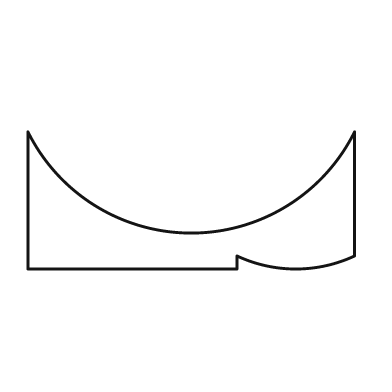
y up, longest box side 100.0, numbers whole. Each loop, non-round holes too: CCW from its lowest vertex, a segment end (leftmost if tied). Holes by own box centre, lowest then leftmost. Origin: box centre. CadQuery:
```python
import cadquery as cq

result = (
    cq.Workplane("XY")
    .moveTo(-50.0, -21.0)
    .lineTo(14.0, -21.0)
    .lineTo(14.0, -17.0)
    .threePointArc((32.0, -21.0), (50.0, -17.0))
    .lineTo(50.0, 21.0)
    .threePointArc((0.0, -10.0), (-50.0, 21.0))
    .close()
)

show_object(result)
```